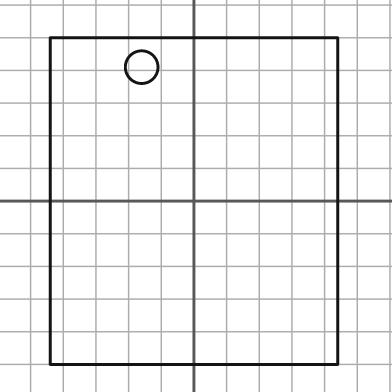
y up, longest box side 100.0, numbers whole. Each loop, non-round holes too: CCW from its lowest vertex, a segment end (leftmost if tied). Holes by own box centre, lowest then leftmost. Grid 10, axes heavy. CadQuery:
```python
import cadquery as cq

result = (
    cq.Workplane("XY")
    .moveTo(-44.0, -50.0)
    .lineTo(44.0, -50.0)
    .lineTo(44.0, 50.0)
    .lineTo(-44.0, 50.0)
    .close()
    .moveTo(-16.0, 41.0)
    .circle(5.0)
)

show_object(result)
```